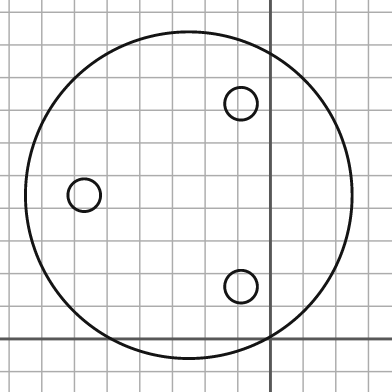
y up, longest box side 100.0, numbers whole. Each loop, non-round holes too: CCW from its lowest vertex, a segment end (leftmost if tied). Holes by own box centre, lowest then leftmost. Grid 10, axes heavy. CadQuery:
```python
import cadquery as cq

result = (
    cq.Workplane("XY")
    .moveTo(-25.0, 44.0)
    .circle(50.0)
    .moveTo(-9.0, 16.0)
    .circle(5.0)
    .moveTo(-57.0, 44.0)
    .circle(5.0)
    .moveTo(-9.0, 72.0)
    .circle(5.0)
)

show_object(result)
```